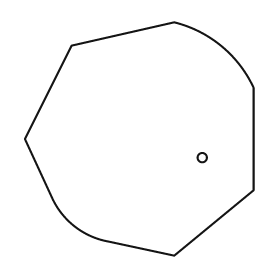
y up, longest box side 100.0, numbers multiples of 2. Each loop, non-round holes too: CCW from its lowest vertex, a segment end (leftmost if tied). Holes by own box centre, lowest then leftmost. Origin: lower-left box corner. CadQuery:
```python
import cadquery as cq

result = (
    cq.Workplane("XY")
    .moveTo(64.0, 0.0)
    .lineTo(98.0, 28.0)
    .lineTo(98.0, 72.0)
    .threePointArc((84.0, 90.0), (64.0, 100.0))
    .lineTo(20.0, 90.0)
    .lineTo(0.0, 50.0)
    .lineTo(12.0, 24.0)
    .threePointArc((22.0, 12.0), (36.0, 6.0))
    .close()
    .moveTo(76.0, 42.0)
    .circle(2.0)
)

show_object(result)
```